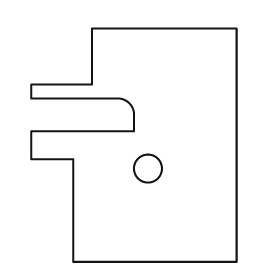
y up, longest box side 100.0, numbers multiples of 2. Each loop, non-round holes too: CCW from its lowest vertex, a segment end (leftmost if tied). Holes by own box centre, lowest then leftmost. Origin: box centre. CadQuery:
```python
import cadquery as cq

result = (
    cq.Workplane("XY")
    .moveTo(-26.0, -50.0)
    .lineTo(44.0, -50.0)
    .lineTo(44.0, 50.0)
    .lineTo(-18.0, 50.0)
    .lineTo(-18.0, 26.0)
    .lineTo(-44.0, 26.0)
    .lineTo(-44.0, 20.0)
    .lineTo(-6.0, 20.0)
    .threePointArc((-2.0, 18.0), (0.0, 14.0))
    .lineTo(0.0, 6.0)
    .lineTo(-44.0, 6.0)
    .lineTo(-44.0, -6.0)
    .lineTo(-26.0, -6.0)
    .close()
    .moveTo(6.0, -10.0)
    .circle(6.0)
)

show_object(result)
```